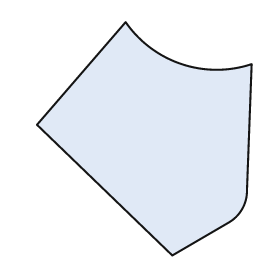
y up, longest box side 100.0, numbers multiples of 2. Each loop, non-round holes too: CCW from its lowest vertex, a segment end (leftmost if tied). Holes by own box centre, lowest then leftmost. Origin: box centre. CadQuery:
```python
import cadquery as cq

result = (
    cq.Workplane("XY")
    .moveTo(12.0, -50.0)
    .lineTo(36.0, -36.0)
    .threePointArc((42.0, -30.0), (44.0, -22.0))
    .lineTo(46.0, 32.0)
    .threePointArc((16.0, 32.0), (-8.0, 50.0))
    .lineTo(-46.0, 6.0)
    .close()
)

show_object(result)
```